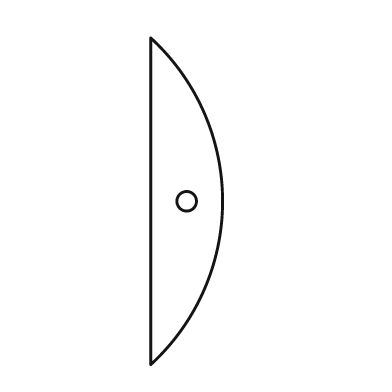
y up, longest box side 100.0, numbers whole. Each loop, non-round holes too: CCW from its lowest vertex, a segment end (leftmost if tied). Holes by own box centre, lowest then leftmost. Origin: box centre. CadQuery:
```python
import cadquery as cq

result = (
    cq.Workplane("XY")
    .moveTo(-11.0, -50.0)
    .threePointArc((11.0, 0.0), (-11.0, 50.0))
    .close()
    .moveTo(0.0, 0.0)
    .circle(3.0)
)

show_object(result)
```